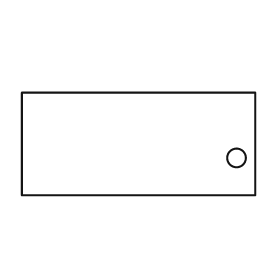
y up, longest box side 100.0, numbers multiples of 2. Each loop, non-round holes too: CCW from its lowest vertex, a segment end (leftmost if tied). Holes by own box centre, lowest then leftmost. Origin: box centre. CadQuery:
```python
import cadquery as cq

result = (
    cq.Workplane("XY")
    .moveTo(-50.0, -22.0)
    .lineTo(50.0, -22.0)
    .lineTo(50.0, 22.0)
    .lineTo(-50.0, 22.0)
    .close()
    .moveTo(42.0, -6.0)
    .circle(4.0)
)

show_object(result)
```